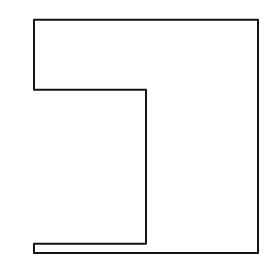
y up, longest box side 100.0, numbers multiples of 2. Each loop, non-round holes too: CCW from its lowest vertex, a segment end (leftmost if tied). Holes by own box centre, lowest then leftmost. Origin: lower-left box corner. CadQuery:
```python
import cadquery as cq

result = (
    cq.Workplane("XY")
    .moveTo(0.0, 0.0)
    .lineTo(96.0, 0.0)
    .lineTo(96.0, 100.0)
    .lineTo(0.0, 100.0)
    .lineTo(0.0, 70.0)
    .lineTo(48.0, 70.0)
    .lineTo(48.0, 4.0)
    .lineTo(0.0, 4.0)
    .close()
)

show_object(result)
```